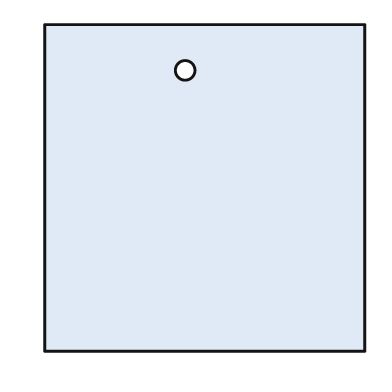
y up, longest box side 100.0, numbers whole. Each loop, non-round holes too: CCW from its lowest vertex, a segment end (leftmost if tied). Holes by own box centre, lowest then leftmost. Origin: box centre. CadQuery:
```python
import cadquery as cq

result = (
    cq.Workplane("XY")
    .moveTo(-49.0, -50.0)
    .lineTo(49.0, -50.0)
    .lineTo(49.0, 50.0)
    .lineTo(-49.0, 50.0)
    .close()
    .moveTo(-6.0, 36.0)
    .circle(3.0)
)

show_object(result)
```